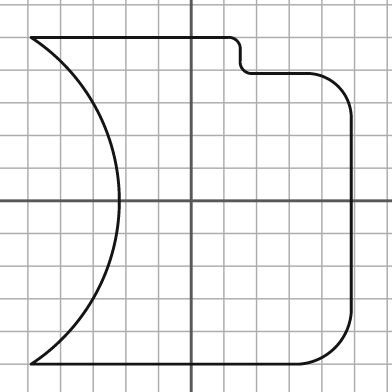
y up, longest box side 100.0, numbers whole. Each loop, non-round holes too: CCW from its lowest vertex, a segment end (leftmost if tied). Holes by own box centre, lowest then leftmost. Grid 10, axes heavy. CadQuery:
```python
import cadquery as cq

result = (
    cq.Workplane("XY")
    .moveTo(-49.0, -50.0)
    .lineTo(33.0, -50.0)
    .threePointArc((44.0, -45.0), (49.0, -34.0))
    .lineTo(49.0, 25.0)
    .threePointArc((45.0, 35.0), (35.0, 39.0))
    .lineTo(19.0, 39.0)
    .threePointArc((16.0, 40.0), (15.0, 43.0))
    .lineTo(15.0, 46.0)
    .threePointArc((14.0, 49.0), (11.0, 50.0))
    .lineTo(-49.0, 50.0)
    .threePointArc((-22.0, 0.0), (-49.0, -50.0))
    .close()
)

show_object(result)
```